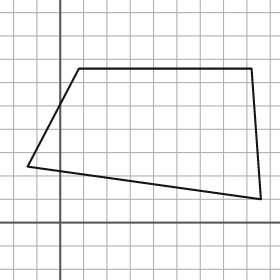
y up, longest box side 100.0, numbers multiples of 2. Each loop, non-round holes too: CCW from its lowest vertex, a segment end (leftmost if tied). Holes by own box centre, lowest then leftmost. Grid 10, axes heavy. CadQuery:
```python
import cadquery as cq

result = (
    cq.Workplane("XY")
    .moveTo(86.0, 10.0)
    .lineTo(82.0, 66.0)
    .lineTo(8.0, 66.0)
    .lineTo(-14.0, 24.0)
    .close()
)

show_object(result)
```